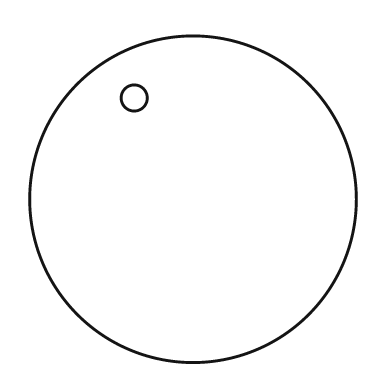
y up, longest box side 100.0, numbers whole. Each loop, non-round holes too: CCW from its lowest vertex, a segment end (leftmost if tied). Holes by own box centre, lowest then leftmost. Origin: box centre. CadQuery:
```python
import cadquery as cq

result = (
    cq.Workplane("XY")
    .moveTo(0.0, 0.0)
    .circle(50.0)
    .moveTo(-18.0, 31.0)
    .circle(4.0)
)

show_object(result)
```